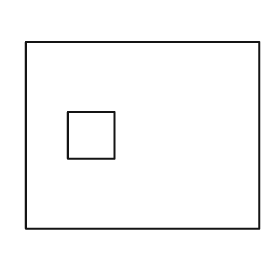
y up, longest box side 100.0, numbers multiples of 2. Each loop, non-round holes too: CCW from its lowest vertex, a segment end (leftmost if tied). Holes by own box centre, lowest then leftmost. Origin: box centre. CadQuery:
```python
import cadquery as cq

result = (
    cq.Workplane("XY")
    .moveTo(-50.0, -40.0)
    .lineTo(50.0, -40.0)
    .lineTo(50.0, 40.0)
    .lineTo(-50.0, 40.0)
    .close()
    .moveTo(-32.0, -10.0)
    .lineTo(-12.0, -10.0)
    .lineTo(-12.0, 10.0)
    .lineTo(-32.0, 10.0)
    .close()
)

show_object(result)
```